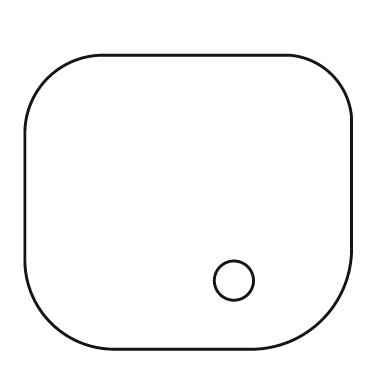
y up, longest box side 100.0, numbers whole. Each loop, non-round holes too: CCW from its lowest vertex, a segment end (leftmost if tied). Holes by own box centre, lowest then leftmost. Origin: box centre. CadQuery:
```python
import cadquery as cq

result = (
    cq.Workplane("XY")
    .moveTo(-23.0, -45.0)
    .lineTo(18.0, -45.0)
    .threePointArc((41.0, -36.0), (50.0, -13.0))
    .lineTo(50.0, 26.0)
    .threePointArc((44.0, 39.0), (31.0, 45.0))
    .lineTo(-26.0, 45.0)
    .threePointArc((-43.0, 38.0), (-50.0, 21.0))
    .lineTo(-50.0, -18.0)
    .threePointArc((-42.0, -37.0), (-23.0, -45.0))
    .close()
    .moveTo(14.0, -24.0)
    .circle(6.0)
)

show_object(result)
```